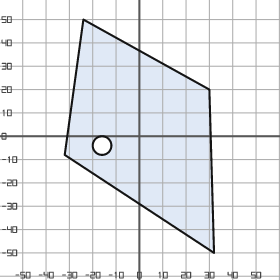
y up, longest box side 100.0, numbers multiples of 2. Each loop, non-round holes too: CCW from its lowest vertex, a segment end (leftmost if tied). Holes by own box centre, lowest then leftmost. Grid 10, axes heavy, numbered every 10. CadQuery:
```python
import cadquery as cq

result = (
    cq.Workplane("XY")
    .moveTo(32.0, -50.0)
    .lineTo(30.0, 20.0)
    .lineTo(-24.0, 50.0)
    .lineTo(-32.0, -8.0)
    .close()
    .moveTo(-16.0, -4.0)
    .circle(4.0)
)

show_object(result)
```